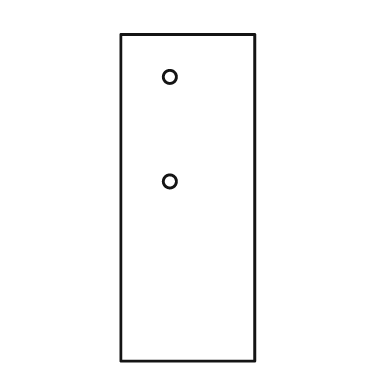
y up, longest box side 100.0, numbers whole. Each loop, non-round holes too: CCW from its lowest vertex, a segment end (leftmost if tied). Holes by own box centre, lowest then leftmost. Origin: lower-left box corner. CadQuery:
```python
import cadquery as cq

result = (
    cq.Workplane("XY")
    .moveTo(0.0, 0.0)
    .lineTo(41.0, 0.0)
    .lineTo(41.0, 100.0)
    .lineTo(0.0, 100.0)
    .close()
    .moveTo(15.0, 55.0)
    .circle(2.0)
    .moveTo(15.0, 87.0)
    .circle(2.0)
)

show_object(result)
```